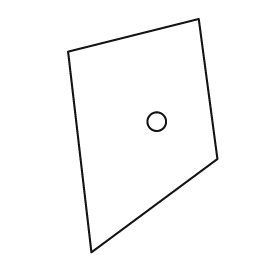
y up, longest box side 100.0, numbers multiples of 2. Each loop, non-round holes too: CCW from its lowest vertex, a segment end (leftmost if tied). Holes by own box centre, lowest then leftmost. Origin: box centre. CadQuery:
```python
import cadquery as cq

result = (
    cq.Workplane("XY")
    .moveTo(-22.0, -50.0)
    .lineTo(32.0, -10.0)
    .lineTo(24.0, 50.0)
    .lineTo(-32.0, 36.0)
    .close()
    .moveTo(6.0, 6.0)
    .circle(4.0)
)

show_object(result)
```